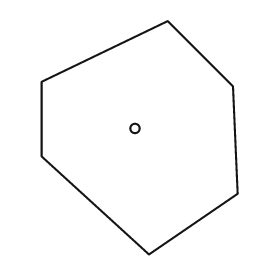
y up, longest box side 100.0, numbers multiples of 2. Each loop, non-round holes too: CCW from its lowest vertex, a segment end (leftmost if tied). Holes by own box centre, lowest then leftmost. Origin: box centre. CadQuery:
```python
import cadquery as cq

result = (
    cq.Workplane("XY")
    .moveTo(4.0, -50.0)
    .lineTo(42.0, -24.0)
    .lineTo(40.0, 22.0)
    .lineTo(12.0, 50.0)
    .lineTo(-42.0, 24.0)
    .lineTo(-42.0, -8.0)
    .close()
    .moveTo(-2.0, 4.0)
    .circle(2.0)
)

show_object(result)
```